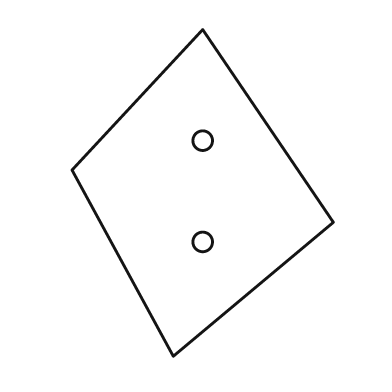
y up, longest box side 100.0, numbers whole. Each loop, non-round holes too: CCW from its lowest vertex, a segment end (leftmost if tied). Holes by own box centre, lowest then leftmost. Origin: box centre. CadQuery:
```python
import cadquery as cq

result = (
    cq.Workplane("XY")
    .moveTo(-9.0, -50.0)
    .lineTo(40.0, -9.0)
    .lineTo(0.0, 50.0)
    .lineTo(-40.0, 7.0)
    .close()
    .moveTo(0.0, -15.0)
    .circle(3.0)
    .moveTo(0.0, 16.0)
    .circle(3.0)
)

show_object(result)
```